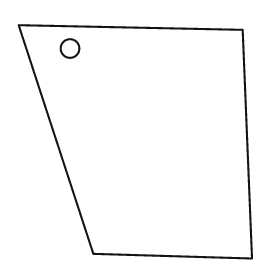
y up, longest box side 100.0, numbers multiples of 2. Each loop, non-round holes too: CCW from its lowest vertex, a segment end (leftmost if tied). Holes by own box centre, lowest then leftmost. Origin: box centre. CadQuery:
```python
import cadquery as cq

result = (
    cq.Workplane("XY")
    .moveTo(50.0, -50.0)
    .lineTo(46.0, 48.0)
    .lineTo(-50.0, 50.0)
    .lineTo(-18.0, -48.0)
    .close()
    .moveTo(-28.0, 40.0)
    .circle(4.0)
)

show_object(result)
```